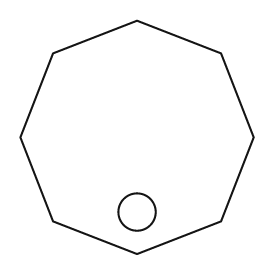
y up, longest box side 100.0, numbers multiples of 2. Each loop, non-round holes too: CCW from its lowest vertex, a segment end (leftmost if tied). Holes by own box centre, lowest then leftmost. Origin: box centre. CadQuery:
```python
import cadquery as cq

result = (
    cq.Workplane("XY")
    .moveTo(0.0, -50.0)
    .lineTo(36.0, -36.0)
    .lineTo(50.0, 0.0)
    .lineTo(36.0, 36.0)
    .lineTo(0.0, 50.0)
    .lineTo(-36.0, 36.0)
    .lineTo(-50.0, 0.0)
    .lineTo(-36.0, -36.0)
    .close()
    .moveTo(0.0, -32.0)
    .circle(8.0)
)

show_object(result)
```